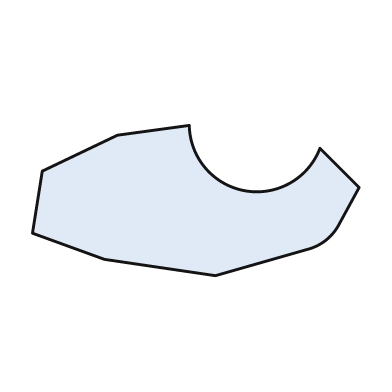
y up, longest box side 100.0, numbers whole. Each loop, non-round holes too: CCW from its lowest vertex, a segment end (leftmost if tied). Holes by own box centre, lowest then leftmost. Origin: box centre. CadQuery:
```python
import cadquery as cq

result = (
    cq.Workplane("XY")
    .moveTo(6.0, -23.0)
    .lineTo(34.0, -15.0)
    .threePointArc((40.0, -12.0), (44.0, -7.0))
    .lineTo(50.0, 4.0)
    .lineTo(38.0, 16.0)
    .threePointArc((15.0, 3.0), (-2.0, 23.0))
    .lineTo(-24.0, 20.0)
    .lineTo(-47.0, 9.0)
    .lineTo(-50.0, -10.0)
    .lineTo(-28.0, -18.0)
    .close()
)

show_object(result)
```